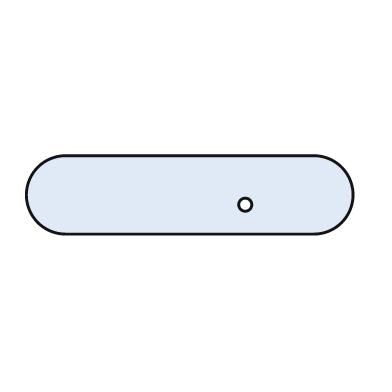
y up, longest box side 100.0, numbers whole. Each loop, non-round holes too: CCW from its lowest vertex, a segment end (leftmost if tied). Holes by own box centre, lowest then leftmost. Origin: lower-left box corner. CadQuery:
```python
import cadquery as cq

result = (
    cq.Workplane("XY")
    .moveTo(12.0, 0.0)
    .lineTo(88.0, 0.0)
    .threePointArc((100.0, 12.0), (88.0, 24.0))
    .lineTo(12.0, 24.0)
    .threePointArc((0.0, 12.0), (12.0, 0.0))
    .close()
    .moveTo(67.0, 9.0)
    .circle(2.0)
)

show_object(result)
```